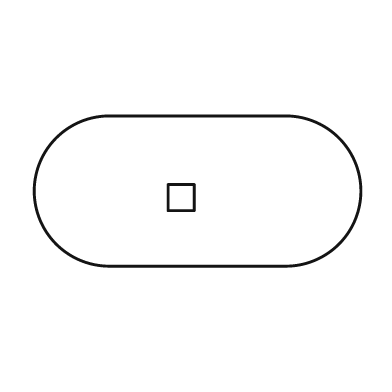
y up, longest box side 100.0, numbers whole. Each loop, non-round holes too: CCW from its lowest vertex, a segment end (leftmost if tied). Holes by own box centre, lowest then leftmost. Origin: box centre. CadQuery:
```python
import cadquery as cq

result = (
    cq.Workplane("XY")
    .moveTo(-27.0, -23.0)
    .lineTo(27.0, -23.0)
    .threePointArc((50.0, 0.0), (27.0, 23.0))
    .lineTo(-27.0, 23.0)
    .threePointArc((-50.0, 0.0), (-27.0, -23.0))
    .close()
    .moveTo(-9.0, -6.0)
    .lineTo(-1.0, -6.0)
    .lineTo(-1.0, 2.0)
    .lineTo(-9.0, 2.0)
    .close()
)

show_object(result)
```